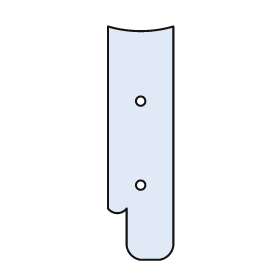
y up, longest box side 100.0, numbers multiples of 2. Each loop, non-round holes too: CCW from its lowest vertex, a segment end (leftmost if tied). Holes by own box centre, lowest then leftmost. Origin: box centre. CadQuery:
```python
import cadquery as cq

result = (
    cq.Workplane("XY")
    .moveTo(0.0, -50.0)
    .lineTo(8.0, -50.0)
    .threePointArc((12.0, -48.0), (14.0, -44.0))
    .lineTo(14.0, 50.0)
    .threePointArc((0.0, 48.0), (-14.0, 50.0))
    .lineTo(-14.0, -28.0)
    .threePointArc((-10.0, -30.0), (-6.0, -28.0))
    .lineTo(-6.0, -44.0)
    .threePointArc((-4.0, -48.0), (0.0, -50.0))
    .close()
    .moveTo(0.0, -18.0)
    .circle(2.0)
    .moveTo(0.0, 18.0)
    .circle(2.0)
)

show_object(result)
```